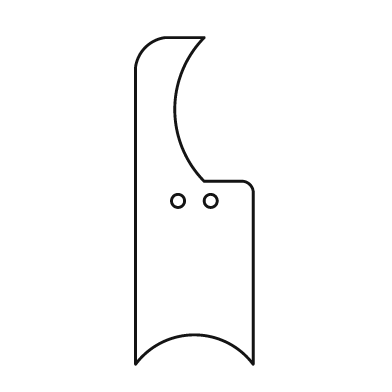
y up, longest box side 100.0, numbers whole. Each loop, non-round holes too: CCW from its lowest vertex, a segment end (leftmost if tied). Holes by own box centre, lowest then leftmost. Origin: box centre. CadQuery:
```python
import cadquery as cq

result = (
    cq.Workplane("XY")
    .moveTo(-18.0, -50.0)
    .threePointArc((0.0, -41.0), (18.0, -50.0))
    .lineTo(18.0, 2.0)
    .threePointArc((17.0, 5.0), (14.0, 6.0))
    .lineTo(3.0, 6.0)
    .threePointArc((-6.0, 28.0), (3.0, 50.0))
    .lineTo(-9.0, 50.0)
    .threePointArc((-15.0, 47.0), (-18.0, 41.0))
    .close()
    .moveTo(-5.0, 0.0)
    .circle(2.0)
    .moveTo(5.0, 0.0)
    .circle(2.0)
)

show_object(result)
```